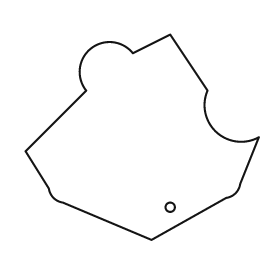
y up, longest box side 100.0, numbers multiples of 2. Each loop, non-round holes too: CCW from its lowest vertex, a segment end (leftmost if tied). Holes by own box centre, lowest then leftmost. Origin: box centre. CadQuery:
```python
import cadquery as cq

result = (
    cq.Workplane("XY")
    .moveTo(4.0, -44.0)
    .lineTo(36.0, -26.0)
    .threePointArc((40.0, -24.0), (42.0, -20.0))
    .lineTo(50.0, 0.0)
    .threePointArc((32.0, 2.0), (28.0, 20.0))
    .lineTo(12.0, 44.0)
    .lineTo(-4.0, 36.0)
    .threePointArc((-22.0, 38.0), (-24.0, 20.0))
    .lineTo(-50.0, -6.0)
    .lineTo(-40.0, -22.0)
    .threePointArc((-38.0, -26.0), (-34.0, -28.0))
    .close()
    .moveTo(12.0, -30.0)
    .circle(2.0)
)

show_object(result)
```